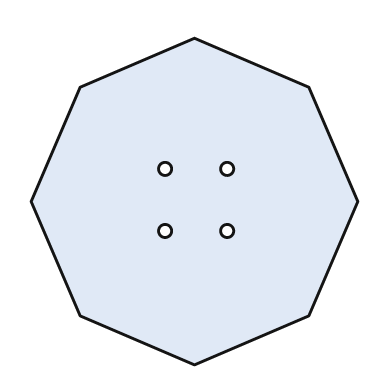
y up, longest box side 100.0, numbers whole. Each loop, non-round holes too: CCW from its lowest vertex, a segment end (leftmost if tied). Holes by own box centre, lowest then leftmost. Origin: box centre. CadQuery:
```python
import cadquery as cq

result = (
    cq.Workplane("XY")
    .moveTo(0.0, -50.0)
    .lineTo(35.0, -35.0)
    .lineTo(50.0, 0.0)
    .lineTo(35.0, 35.0)
    .lineTo(0.0, 50.0)
    .lineTo(-35.0, 35.0)
    .lineTo(-50.0, 0.0)
    .lineTo(-35.0, -35.0)
    .close()
    .moveTo(-9.0, -9.0)
    .circle(2.0)
    .moveTo(10.0, -9.0)
    .circle(2.0)
    .moveTo(-9.0, 10.0)
    .circle(2.0)
    .moveTo(10.0, 10.0)
    .circle(2.0)
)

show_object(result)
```